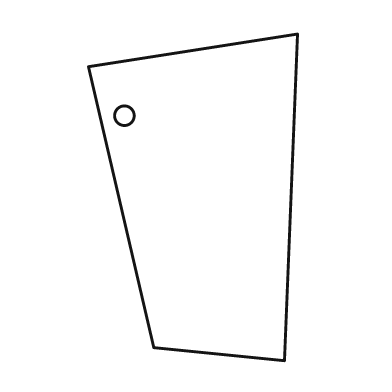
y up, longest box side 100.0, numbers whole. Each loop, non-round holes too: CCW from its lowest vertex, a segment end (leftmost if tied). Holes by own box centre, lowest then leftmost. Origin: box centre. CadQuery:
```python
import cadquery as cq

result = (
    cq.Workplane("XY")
    .moveTo(28.0, -50.0)
    .lineTo(32.0, 50.0)
    .lineTo(-32.0, 40.0)
    .lineTo(-12.0, -46.0)
    .close()
    .moveTo(-21.0, 25.0)
    .circle(3.0)
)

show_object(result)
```